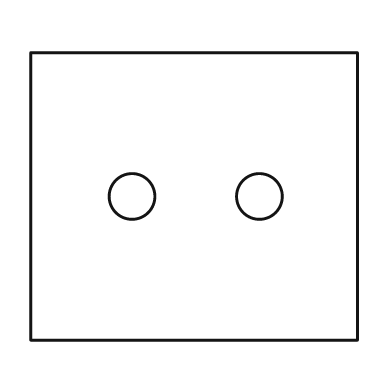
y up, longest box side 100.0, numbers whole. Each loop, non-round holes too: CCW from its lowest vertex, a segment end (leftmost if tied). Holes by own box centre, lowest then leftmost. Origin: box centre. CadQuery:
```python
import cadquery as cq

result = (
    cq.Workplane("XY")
    .moveTo(-50.0, -44.0)
    .lineTo(50.0, -44.0)
    .lineTo(50.0, 44.0)
    .lineTo(-50.0, 44.0)
    .close()
    .moveTo(-19.0, 0.0)
    .circle(7.0)
    .moveTo(20.0, 0.0)
    .circle(7.0)
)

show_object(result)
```